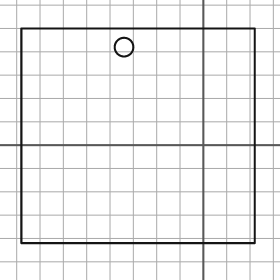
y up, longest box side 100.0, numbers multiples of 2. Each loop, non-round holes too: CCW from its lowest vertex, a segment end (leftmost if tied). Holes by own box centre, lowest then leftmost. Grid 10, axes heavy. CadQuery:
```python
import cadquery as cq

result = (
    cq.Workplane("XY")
    .moveTo(-78.0, -42.0)
    .lineTo(22.0, -42.0)
    .lineTo(22.0, 50.0)
    .lineTo(-78.0, 50.0)
    .close()
    .moveTo(-34.0, 42.0)
    .circle(4.0)
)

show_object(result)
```